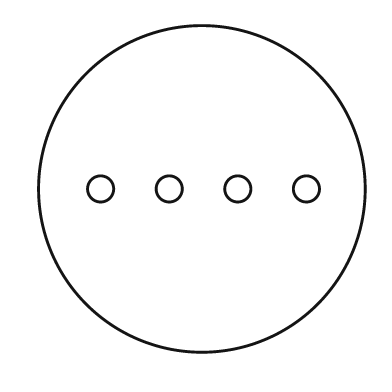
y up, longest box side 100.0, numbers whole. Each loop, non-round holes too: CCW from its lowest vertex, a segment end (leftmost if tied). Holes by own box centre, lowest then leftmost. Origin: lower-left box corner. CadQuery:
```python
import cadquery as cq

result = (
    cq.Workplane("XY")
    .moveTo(50.0, 50.0)
    .circle(50.0)
    .moveTo(19.0, 50.0)
    .circle(4.0)
    .moveTo(40.0, 50.0)
    .circle(4.0)
    .moveTo(61.0, 50.0)
    .circle(4.0)
    .moveTo(82.0, 50.0)
    .circle(4.0)
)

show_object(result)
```